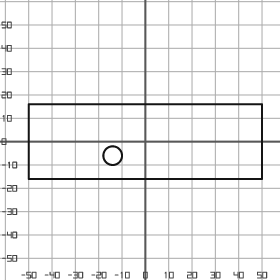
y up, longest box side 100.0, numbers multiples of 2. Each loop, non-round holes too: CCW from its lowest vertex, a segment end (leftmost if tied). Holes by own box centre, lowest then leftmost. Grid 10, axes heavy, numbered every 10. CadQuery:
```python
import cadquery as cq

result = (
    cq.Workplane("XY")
    .moveTo(-50.0, -16.0)
    .lineTo(50.0, -16.0)
    .lineTo(50.0, 16.0)
    .lineTo(-50.0, 16.0)
    .close()
    .moveTo(-14.0, -6.0)
    .circle(4.0)
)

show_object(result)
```